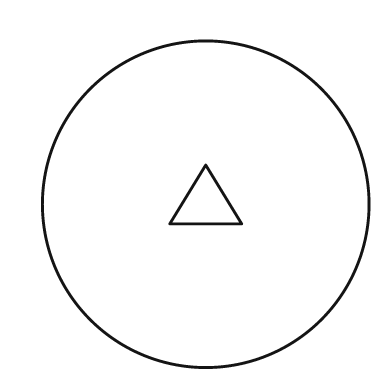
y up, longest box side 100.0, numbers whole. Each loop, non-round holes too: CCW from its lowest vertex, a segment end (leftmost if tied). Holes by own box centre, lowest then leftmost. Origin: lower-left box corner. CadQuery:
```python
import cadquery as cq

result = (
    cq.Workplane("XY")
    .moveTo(50.0, 50.0)
    .circle(50.0)
    .moveTo(39.0, 44.0)
    .lineTo(61.0, 44.0)
    .lineTo(50.0, 62.0)
    .close()
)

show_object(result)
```